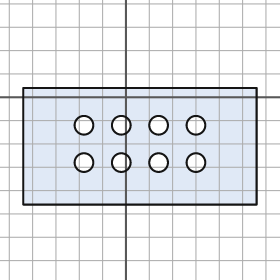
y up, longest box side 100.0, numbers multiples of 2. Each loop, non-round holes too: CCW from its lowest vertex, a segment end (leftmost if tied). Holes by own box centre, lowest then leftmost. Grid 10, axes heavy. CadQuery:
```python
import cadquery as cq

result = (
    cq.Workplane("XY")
    .moveTo(-44.0, -46.0)
    .lineTo(56.0, -46.0)
    .lineTo(56.0, 4.0)
    .lineTo(-44.0, 4.0)
    .close()
    .moveTo(-18.0, -28.0)
    .circle(4.0)
    .moveTo(-2.0, -28.0)
    .circle(4.0)
    .moveTo(14.0, -28.0)
    .circle(4.0)
    .moveTo(30.0, -28.0)
    .circle(4.0)
    .moveTo(-18.0, -12.0)
    .circle(4.0)
    .moveTo(-2.0, -12.0)
    .circle(4.0)
    .moveTo(14.0, -12.0)
    .circle(4.0)
    .moveTo(30.0, -12.0)
    .circle(4.0)
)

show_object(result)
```